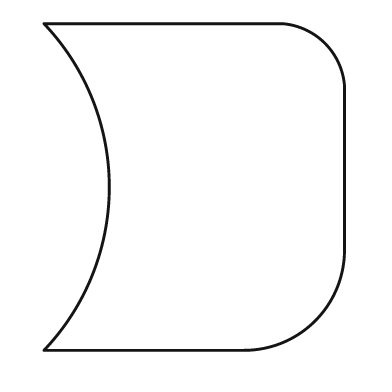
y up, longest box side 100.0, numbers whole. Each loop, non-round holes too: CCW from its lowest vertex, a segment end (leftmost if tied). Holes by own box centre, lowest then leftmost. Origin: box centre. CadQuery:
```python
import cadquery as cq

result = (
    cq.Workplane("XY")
    .moveTo(-46.0, -50.0)
    .lineTo(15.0, -50.0)
    .threePointArc((37.0, -41.0), (46.0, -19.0))
    .lineTo(46.0, 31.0)
    .threePointArc((40.0, 44.0), (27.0, 50.0))
    .lineTo(-46.0, 50.0)
    .threePointArc((-26.0, 0.0), (-46.0, -50.0))
    .close()
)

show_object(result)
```